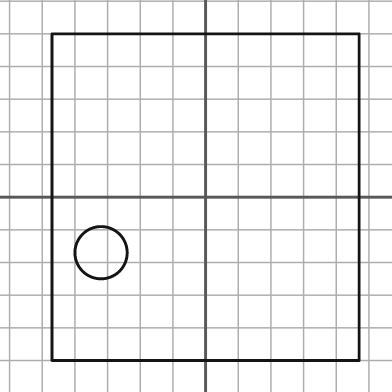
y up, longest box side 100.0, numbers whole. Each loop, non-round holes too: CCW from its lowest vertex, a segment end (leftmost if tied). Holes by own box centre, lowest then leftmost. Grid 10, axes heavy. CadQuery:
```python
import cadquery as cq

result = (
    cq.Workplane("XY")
    .moveTo(-47.0, -50.0)
    .lineTo(47.0, -50.0)
    .lineTo(47.0, 50.0)
    .lineTo(-47.0, 50.0)
    .close()
    .moveTo(-32.0, -17.0)
    .circle(8.0)
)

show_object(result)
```